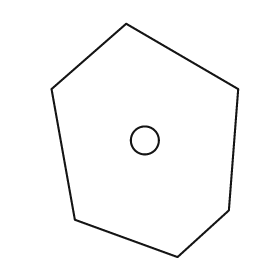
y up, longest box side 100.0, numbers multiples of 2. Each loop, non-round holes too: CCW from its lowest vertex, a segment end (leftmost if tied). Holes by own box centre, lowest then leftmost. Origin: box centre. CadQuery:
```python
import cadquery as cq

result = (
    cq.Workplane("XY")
    .moveTo(14.0, -50.0)
    .lineTo(36.0, -30.0)
    .lineTo(40.0, 22.0)
    .lineTo(-8.0, 50.0)
    .lineTo(-40.0, 22.0)
    .lineTo(-30.0, -34.0)
    .close()
    .moveTo(0.0, 0.0)
    .circle(6.0)
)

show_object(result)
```